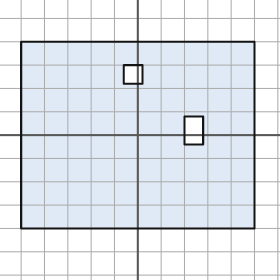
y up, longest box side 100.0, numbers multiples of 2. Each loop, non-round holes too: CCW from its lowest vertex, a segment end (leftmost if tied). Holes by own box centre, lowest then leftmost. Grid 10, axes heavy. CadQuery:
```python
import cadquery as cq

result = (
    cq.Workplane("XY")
    .moveTo(-50.0, -40.0)
    .lineTo(50.0, -40.0)
    .lineTo(50.0, 40.0)
    .lineTo(-50.0, 40.0)
    .close()
    .moveTo(20.0, -4.0)
    .lineTo(28.0, -4.0)
    .lineTo(28.0, 8.0)
    .lineTo(20.0, 8.0)
    .close()
    .moveTo(-6.0, 22.0)
    .lineTo(2.0, 22.0)
    .lineTo(2.0, 30.0)
    .lineTo(-6.0, 30.0)
    .close()
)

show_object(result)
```